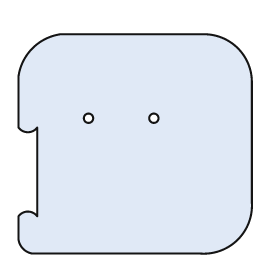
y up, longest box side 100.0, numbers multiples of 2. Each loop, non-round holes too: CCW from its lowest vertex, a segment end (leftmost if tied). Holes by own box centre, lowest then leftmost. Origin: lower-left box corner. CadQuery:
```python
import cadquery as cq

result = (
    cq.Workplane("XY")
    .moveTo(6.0, 0.0)
    .lineTo(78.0, 0.0)
    .threePointArc((94.0, 6.0), (100.0, 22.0))
    .lineTo(100.0, 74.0)
    .threePointArc((94.0, 88.0), (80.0, 94.0))
    .lineTo(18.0, 94.0)
    .threePointArc((6.0, 88.0), (0.0, 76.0))
    .lineTo(0.0, 54.0)
    .threePointArc((4.0, 52.0), (8.0, 54.0))
    .lineTo(8.0, 16.0)
    .threePointArc((4.0, 18.0), (0.0, 16.0))
    .lineTo(0.0, 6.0)
    .threePointArc((2.0, 2.0), (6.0, 0.0))
    .close()
    .moveTo(30.0, 58.0)
    .circle(2.0)
    .moveTo(58.0, 58.0)
    .circle(2.0)
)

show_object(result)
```